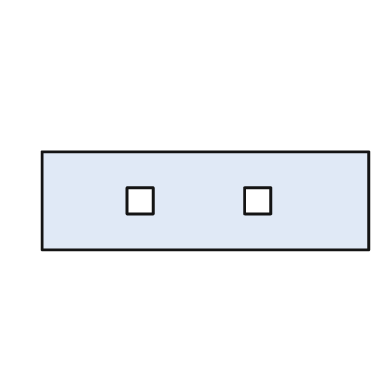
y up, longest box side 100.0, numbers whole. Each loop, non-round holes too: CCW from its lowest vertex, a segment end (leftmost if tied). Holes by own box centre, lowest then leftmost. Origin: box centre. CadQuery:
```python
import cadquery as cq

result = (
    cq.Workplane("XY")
    .moveTo(-50.0, -15.0)
    .lineTo(50.0, -15.0)
    .lineTo(50.0, 15.0)
    .lineTo(-50.0, 15.0)
    .close()
    .moveTo(-24.0, -4.0)
    .lineTo(-16.0, -4.0)
    .lineTo(-16.0, 4.0)
    .lineTo(-24.0, 4.0)
    .close()
    .moveTo(12.0, -4.0)
    .lineTo(20.0, -4.0)
    .lineTo(20.0, 4.0)
    .lineTo(12.0, 4.0)
    .close()
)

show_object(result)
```